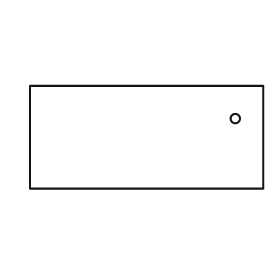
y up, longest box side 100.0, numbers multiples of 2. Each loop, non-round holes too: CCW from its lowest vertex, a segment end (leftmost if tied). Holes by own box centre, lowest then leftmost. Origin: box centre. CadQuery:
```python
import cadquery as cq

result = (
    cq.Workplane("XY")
    .moveTo(-50.0, -22.0)
    .lineTo(50.0, -22.0)
    .lineTo(50.0, 22.0)
    .lineTo(-50.0, 22.0)
    .close()
    .moveTo(38.0, 8.0)
    .circle(2.0)
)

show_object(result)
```